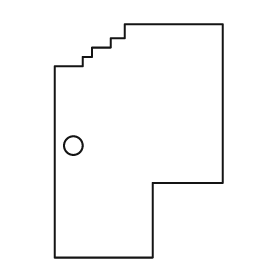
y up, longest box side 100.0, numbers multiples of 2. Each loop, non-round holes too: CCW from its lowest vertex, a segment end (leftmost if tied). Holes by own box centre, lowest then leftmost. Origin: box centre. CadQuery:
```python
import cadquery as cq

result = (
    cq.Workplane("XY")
    .moveTo(-36.0, -50.0)
    .lineTo(6.0, -50.0)
    .lineTo(6.0, -18.0)
    .lineTo(36.0, -18.0)
    .lineTo(36.0, 50.0)
    .lineTo(-6.0, 50.0)
    .lineTo(-6.0, 44.0)
    .lineTo(-12.0, 44.0)
    .lineTo(-12.0, 40.0)
    .lineTo(-20.0, 40.0)
    .lineTo(-20.0, 36.0)
    .lineTo(-24.0, 36.0)
    .lineTo(-24.0, 32.0)
    .lineTo(-36.0, 32.0)
    .close()
    .moveTo(-28.0, -2.0)
    .circle(4.0)
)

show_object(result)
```